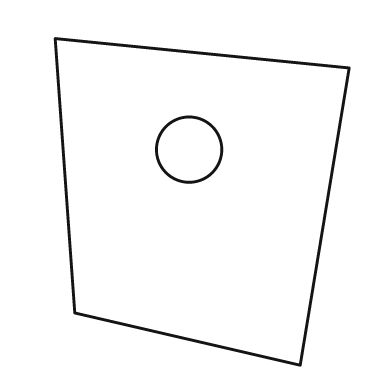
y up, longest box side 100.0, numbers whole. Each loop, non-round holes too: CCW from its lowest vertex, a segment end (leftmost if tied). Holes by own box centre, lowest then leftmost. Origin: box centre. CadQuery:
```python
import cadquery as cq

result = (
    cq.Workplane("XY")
    .moveTo(30.0, -50.0)
    .lineTo(45.0, 41.0)
    .lineTo(-45.0, 50.0)
    .lineTo(-39.0, -34.0)
    .close()
    .moveTo(-4.0, 16.0)
    .circle(10.0)
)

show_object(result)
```